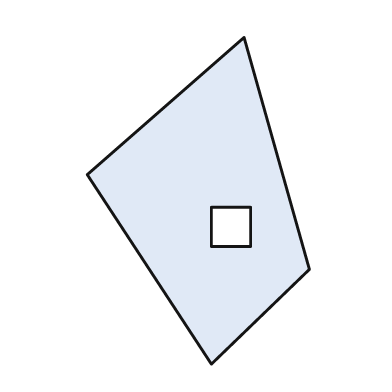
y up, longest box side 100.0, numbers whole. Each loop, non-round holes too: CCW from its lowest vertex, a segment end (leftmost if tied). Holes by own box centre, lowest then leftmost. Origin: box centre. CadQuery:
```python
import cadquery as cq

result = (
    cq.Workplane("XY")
    .moveTo(4.0, -50.0)
    .lineTo(34.0, -21.0)
    .lineTo(14.0, 50.0)
    .lineTo(-34.0, 8.0)
    .close()
    .moveTo(4.0, -14.0)
    .lineTo(16.0, -14.0)
    .lineTo(16.0, -2.0)
    .lineTo(4.0, -2.0)
    .close()
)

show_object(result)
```